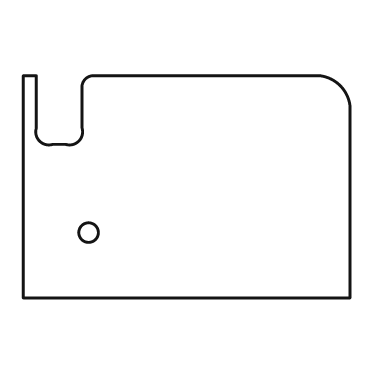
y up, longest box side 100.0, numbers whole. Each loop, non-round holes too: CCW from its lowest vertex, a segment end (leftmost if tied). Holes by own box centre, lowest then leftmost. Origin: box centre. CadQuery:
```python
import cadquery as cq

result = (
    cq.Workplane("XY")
    .moveTo(-50.0, -34.0)
    .lineTo(50.0, -34.0)
    .lineTo(50.0, 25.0)
    .threePointArc((47.0, 31.0), (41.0, 34.0))
    .lineTo(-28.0, 34.0)
    .threePointArc((-31.0, 33.0), (-32.0, 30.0))
    .lineTo(-32.0, 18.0)
    .threePointArc((-33.0, 14.0), (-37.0, 13.0))
    .lineTo(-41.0, 13.0)
    .threePointArc((-45.0, 14.0), (-46.0, 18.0))
    .lineTo(-46.0, 34.0)
    .lineTo(-50.0, 34.0)
    .close()
    .moveTo(-30.0, -14.0)
    .circle(3.0)
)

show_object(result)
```